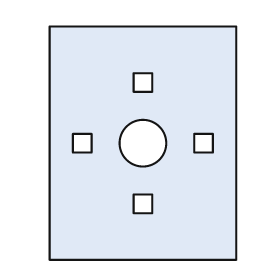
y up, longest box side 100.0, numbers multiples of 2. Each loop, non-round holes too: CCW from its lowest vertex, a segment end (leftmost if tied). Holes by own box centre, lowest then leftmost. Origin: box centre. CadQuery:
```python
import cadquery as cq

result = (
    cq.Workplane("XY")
    .moveTo(-40.0, -50.0)
    .lineTo(40.0, -50.0)
    .lineTo(40.0, 50.0)
    .lineTo(-40.0, 50.0)
    .close()
    .moveTo(-4.0, -30.0)
    .lineTo(4.0, -30.0)
    .lineTo(4.0, -22.0)
    .lineTo(-4.0, -22.0)
    .close()
    .moveTo(-30.0, -4.0)
    .lineTo(-22.0, -4.0)
    .lineTo(-22.0, 4.0)
    .lineTo(-30.0, 4.0)
    .close()
    .moveTo(0.0, 0.0)
    .circle(10.0)
    .moveTo(22.0, -4.0)
    .lineTo(30.0, -4.0)
    .lineTo(30.0, 4.0)
    .lineTo(22.0, 4.0)
    .close()
    .moveTo(-4.0, 22.0)
    .lineTo(4.0, 22.0)
    .lineTo(4.0, 30.0)
    .lineTo(-4.0, 30.0)
    .close()
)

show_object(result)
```